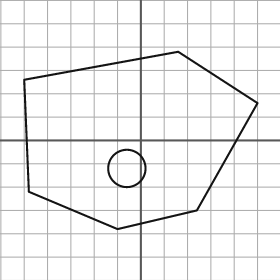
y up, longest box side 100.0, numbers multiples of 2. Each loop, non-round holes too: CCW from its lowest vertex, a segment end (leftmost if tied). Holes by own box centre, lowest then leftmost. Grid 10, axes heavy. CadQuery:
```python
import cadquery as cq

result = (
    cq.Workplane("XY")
    .moveTo(-10.0, -38.0)
    .lineTo(24.0, -30.0)
    .lineTo(50.0, 16.0)
    .lineTo(16.0, 38.0)
    .lineTo(-50.0, 26.0)
    .lineTo(-48.0, -22.0)
    .close()
    .moveTo(-6.0, -12.0)
    .circle(8.0)
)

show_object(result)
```